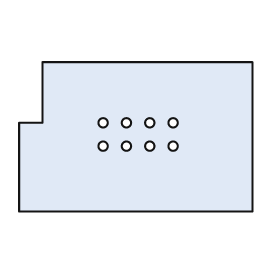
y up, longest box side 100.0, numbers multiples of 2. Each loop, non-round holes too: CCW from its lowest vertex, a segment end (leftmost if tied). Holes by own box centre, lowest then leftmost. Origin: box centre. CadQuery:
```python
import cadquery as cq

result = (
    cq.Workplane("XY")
    .moveTo(-50.0, -32.0)
    .lineTo(50.0, -32.0)
    .lineTo(50.0, 32.0)
    .lineTo(-40.0, 32.0)
    .lineTo(-40.0, 6.0)
    .lineTo(-50.0, 6.0)
    .close()
    .moveTo(-14.0, -4.0)
    .circle(2.0)
    .moveTo(-4.0, -4.0)
    .circle(2.0)
    .moveTo(6.0, -4.0)
    .circle(2.0)
    .moveTo(16.0, -4.0)
    .circle(2.0)
    .moveTo(-14.0, 6.0)
    .circle(2.0)
    .moveTo(-4.0, 6.0)
    .circle(2.0)
    .moveTo(6.0, 6.0)
    .circle(2.0)
    .moveTo(16.0, 6.0)
    .circle(2.0)
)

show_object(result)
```